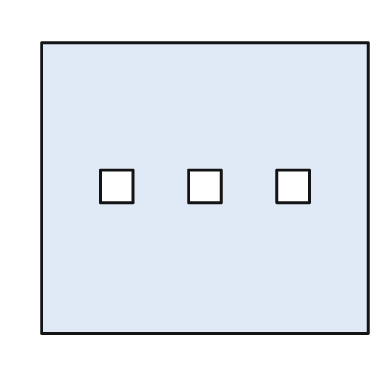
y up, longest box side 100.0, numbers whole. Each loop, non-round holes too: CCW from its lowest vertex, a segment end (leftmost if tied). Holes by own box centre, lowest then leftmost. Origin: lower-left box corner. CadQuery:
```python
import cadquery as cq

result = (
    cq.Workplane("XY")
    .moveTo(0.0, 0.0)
    .lineTo(100.0, 0.0)
    .lineTo(100.0, 89.0)
    .lineTo(0.0, 89.0)
    .close()
    .moveTo(18.0, 40.0)
    .lineTo(28.0, 40.0)
    .lineTo(28.0, 50.0)
    .lineTo(18.0, 50.0)
    .close()
    .moveTo(45.0, 40.0)
    .lineTo(55.0, 40.0)
    .lineTo(55.0, 50.0)
    .lineTo(45.0, 50.0)
    .close()
    .moveTo(72.0, 40.0)
    .lineTo(82.0, 40.0)
    .lineTo(82.0, 50.0)
    .lineTo(72.0, 50.0)
    .close()
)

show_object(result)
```